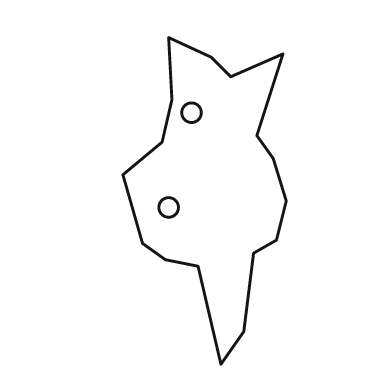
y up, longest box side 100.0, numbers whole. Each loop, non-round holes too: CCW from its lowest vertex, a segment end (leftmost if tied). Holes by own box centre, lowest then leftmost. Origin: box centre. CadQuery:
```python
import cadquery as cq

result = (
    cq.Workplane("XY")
    .moveTo(5.0, -50.0)
    .lineTo(12.0, -40.0)
    .lineTo(15.0, -16.0)
    .lineTo(22.0, -12.0)
    .lineTo(25.0, 0.0)
    .lineTo(21.0, 13.0)
    .lineTo(16.0, 20.0)
    .lineTo(24.0, 45.0)
    .lineTo(8.0, 38.0)
    .lineTo(2.0, 44.0)
    .lineTo(-11.0, 50.0)
    .lineTo(-10.0, 31.0)
    .lineTo(-13.0, 18.0)
    .lineTo(-25.0, 8.0)
    .lineTo(-19.0, -13.0)
    .lineTo(-12.0, -18.0)
    .lineTo(-2.0, -20.0)
    .close()
    .moveTo(-11.0, -2.0)
    .circle(3.0)
    .moveTo(-4.0, 27.0)
    .circle(3.0)
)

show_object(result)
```